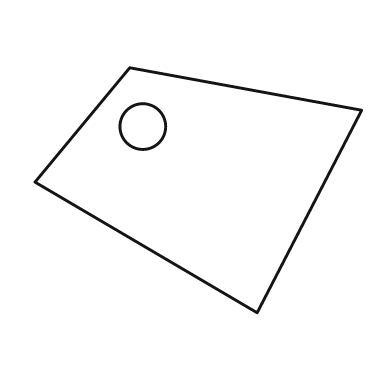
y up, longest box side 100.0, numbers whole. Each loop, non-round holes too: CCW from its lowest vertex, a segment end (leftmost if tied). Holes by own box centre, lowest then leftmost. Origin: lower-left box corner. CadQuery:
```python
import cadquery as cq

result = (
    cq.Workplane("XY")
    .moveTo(68.0, 0.0)
    .lineTo(100.0, 62.0)
    .lineTo(29.0, 75.0)
    .lineTo(0.0, 40.0)
    .close()
    .moveTo(33.0, 57.0)
    .circle(7.0)
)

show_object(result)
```